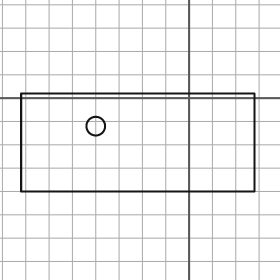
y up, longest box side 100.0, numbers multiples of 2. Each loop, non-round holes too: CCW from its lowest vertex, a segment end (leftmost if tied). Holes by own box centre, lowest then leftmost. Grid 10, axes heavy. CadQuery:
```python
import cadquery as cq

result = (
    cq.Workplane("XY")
    .moveTo(-72.0, -40.0)
    .lineTo(28.0, -40.0)
    .lineTo(28.0, 2.0)
    .lineTo(-72.0, 2.0)
    .close()
    .moveTo(-40.0, -12.0)
    .circle(4.0)
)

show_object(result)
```